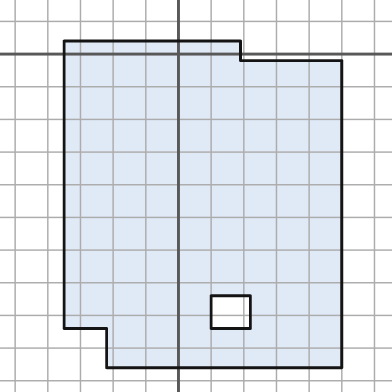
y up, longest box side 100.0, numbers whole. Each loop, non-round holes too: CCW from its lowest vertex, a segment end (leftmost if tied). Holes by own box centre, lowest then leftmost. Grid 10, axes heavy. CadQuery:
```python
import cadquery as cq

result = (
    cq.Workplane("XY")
    .moveTo(-22.0, -96.0)
    .lineTo(50.0, -96.0)
    .lineTo(50.0, -2.0)
    .lineTo(19.0, -2.0)
    .lineTo(19.0, 4.0)
    .lineTo(-35.0, 4.0)
    .lineTo(-35.0, -84.0)
    .lineTo(-22.0, -84.0)
    .close()
    .moveTo(10.0, -84.0)
    .lineTo(22.0, -84.0)
    .lineTo(22.0, -74.0)
    .lineTo(10.0, -74.0)
    .close()
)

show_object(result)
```